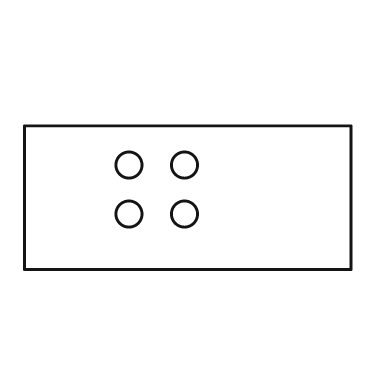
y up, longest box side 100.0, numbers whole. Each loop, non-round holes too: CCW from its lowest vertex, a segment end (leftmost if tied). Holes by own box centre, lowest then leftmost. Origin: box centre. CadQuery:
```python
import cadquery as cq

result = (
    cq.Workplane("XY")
    .moveTo(-50.0, -22.0)
    .lineTo(50.0, -22.0)
    .lineTo(50.0, 22.0)
    .lineTo(-50.0, 22.0)
    .close()
    .moveTo(-18.0, -5.0)
    .circle(4.0)
    .moveTo(-1.0, -5.0)
    .circle(4.0)
    .moveTo(-18.0, 10.0)
    .circle(4.0)
    .moveTo(-1.0, 10.0)
    .circle(4.0)
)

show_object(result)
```